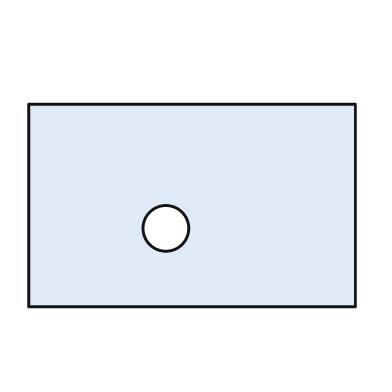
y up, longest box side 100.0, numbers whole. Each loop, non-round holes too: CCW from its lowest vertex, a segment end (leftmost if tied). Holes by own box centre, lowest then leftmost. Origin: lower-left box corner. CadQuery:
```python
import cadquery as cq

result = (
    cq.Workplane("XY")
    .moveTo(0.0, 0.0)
    .lineTo(100.0, 0.0)
    .lineTo(100.0, 62.0)
    .lineTo(0.0, 62.0)
    .close()
    .moveTo(42.0, 24.0)
    .circle(7.0)
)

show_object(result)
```